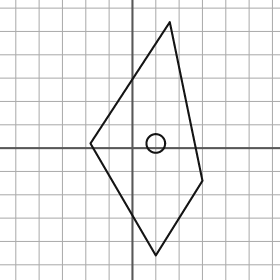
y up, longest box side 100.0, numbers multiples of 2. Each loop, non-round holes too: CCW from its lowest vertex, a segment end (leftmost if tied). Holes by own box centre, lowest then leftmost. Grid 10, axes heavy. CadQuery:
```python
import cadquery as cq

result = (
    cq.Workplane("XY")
    .moveTo(10.0, -46.0)
    .lineTo(30.0, -14.0)
    .lineTo(16.0, 54.0)
    .lineTo(-18.0, 2.0)
    .close()
    .moveTo(10.0, 2.0)
    .circle(4.0)
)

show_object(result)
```